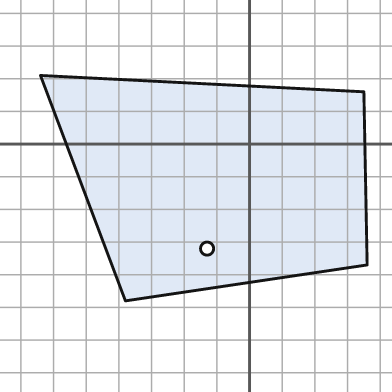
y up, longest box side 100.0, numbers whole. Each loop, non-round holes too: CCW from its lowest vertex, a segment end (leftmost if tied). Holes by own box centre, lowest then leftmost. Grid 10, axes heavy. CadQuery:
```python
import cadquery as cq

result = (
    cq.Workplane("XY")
    .moveTo(-38.0, -48.0)
    .lineTo(36.0, -37.0)
    .lineTo(35.0, 16.0)
    .lineTo(-64.0, 21.0)
    .close()
    .moveTo(-13.0, -32.0)
    .circle(2.0)
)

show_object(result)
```